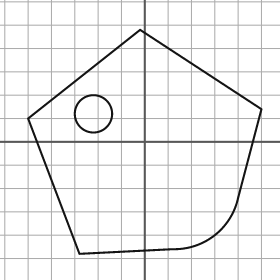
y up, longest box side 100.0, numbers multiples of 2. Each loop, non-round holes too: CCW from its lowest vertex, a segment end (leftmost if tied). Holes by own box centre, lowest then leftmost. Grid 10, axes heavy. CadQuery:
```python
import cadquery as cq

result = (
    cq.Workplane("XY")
    .moveTo(-28.0, -48.0)
    .lineTo(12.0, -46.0)
    .threePointArc((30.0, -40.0), (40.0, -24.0))
    .lineTo(50.0, 14.0)
    .lineTo(-2.0, 48.0)
    .lineTo(-50.0, 10.0)
    .close()
    .moveTo(-22.0, 12.0)
    .circle(8.0)
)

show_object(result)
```